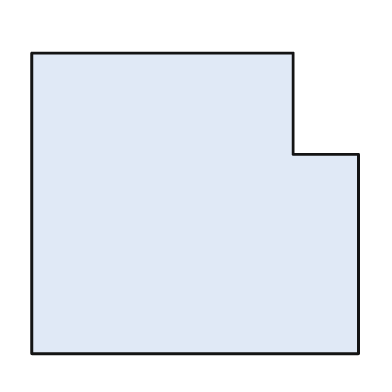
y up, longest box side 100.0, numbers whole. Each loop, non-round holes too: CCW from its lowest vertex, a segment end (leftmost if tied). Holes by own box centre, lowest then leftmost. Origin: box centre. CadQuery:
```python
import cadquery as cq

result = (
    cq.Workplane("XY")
    .moveTo(-50.0, -46.0)
    .lineTo(50.0, -46.0)
    .lineTo(50.0, 15.0)
    .lineTo(30.0, 15.0)
    .lineTo(30.0, 46.0)
    .lineTo(-50.0, 46.0)
    .close()
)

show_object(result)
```